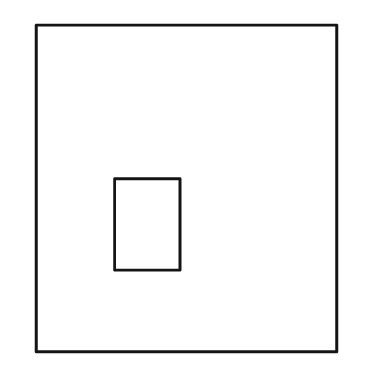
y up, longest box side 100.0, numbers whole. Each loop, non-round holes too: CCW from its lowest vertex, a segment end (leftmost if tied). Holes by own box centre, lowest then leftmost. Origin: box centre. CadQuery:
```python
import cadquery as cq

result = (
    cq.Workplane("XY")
    .moveTo(-46.0, -50.0)
    .lineTo(46.0, -50.0)
    .lineTo(46.0, 50.0)
    .lineTo(-46.0, 50.0)
    .close()
    .moveTo(-22.0, -25.0)
    .lineTo(-2.0, -25.0)
    .lineTo(-2.0, 3.0)
    .lineTo(-22.0, 3.0)
    .close()
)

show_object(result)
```